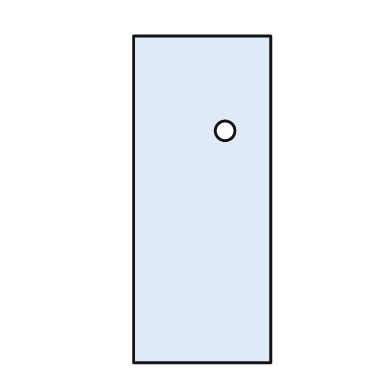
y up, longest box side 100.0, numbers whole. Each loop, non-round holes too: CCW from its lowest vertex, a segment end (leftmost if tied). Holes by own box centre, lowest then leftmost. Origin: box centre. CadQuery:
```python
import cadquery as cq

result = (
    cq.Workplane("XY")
    .moveTo(-21.0, -50.0)
    .lineTo(21.0, -50.0)
    .lineTo(21.0, 50.0)
    .lineTo(-21.0, 50.0)
    .close()
    .moveTo(7.0, 21.0)
    .circle(3.0)
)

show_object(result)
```